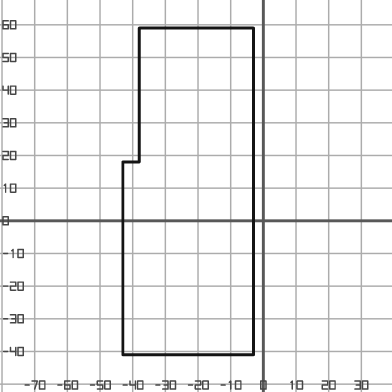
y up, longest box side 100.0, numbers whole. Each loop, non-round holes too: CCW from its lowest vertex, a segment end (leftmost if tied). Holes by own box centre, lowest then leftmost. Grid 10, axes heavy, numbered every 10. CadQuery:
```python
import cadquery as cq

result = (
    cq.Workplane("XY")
    .moveTo(-43.0, -41.0)
    .lineTo(-3.0, -41.0)
    .lineTo(-3.0, 59.0)
    .lineTo(-38.0, 59.0)
    .lineTo(-38.0, 18.0)
    .lineTo(-43.0, 18.0)
    .close()
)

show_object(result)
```